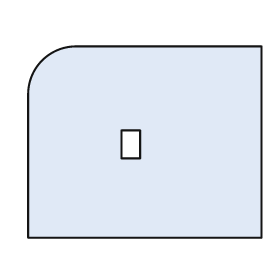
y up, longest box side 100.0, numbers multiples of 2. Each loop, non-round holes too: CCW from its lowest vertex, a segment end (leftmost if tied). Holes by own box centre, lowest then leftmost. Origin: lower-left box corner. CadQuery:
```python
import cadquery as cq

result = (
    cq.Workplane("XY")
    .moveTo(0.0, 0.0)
    .lineTo(100.0, 0.0)
    .lineTo(100.0, 82.0)
    .lineTo(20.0, 82.0)
    .threePointArc((6.0, 76.0), (0.0, 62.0))
    .close()
    .moveTo(40.0, 34.0)
    .lineTo(48.0, 34.0)
    .lineTo(48.0, 46.0)
    .lineTo(40.0, 46.0)
    .close()
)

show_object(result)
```